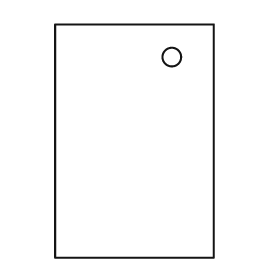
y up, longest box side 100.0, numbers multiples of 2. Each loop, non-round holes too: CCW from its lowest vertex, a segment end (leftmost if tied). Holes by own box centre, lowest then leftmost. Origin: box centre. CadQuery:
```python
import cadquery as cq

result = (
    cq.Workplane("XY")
    .moveTo(-34.0, -50.0)
    .lineTo(34.0, -50.0)
    .lineTo(34.0, 50.0)
    .lineTo(-34.0, 50.0)
    .close()
    .moveTo(16.0, 36.0)
    .circle(4.0)
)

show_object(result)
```